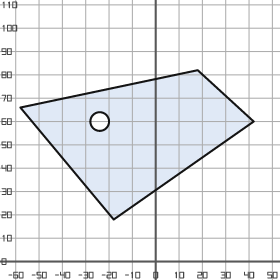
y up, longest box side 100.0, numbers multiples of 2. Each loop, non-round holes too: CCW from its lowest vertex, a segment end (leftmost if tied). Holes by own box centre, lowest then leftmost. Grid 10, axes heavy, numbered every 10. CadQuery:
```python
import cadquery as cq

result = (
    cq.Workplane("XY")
    .moveTo(-18.0, 18.0)
    .lineTo(42.0, 60.0)
    .lineTo(18.0, 82.0)
    .lineTo(-58.0, 66.0)
    .close()
    .moveTo(-24.0, 60.0)
    .circle(4.0)
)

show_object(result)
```